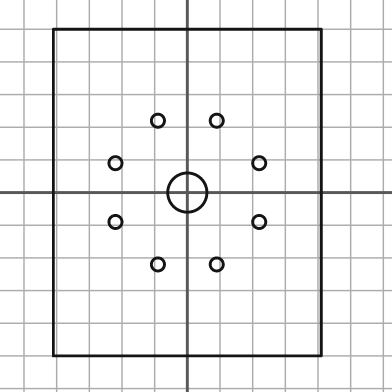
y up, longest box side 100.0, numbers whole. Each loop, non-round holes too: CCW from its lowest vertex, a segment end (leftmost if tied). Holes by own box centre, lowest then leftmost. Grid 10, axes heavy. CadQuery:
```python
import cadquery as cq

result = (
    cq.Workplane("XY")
    .moveTo(-41.0, -50.0)
    .lineTo(41.0, -50.0)
    .lineTo(41.0, 50.0)
    .lineTo(-41.0, 50.0)
    .close()
    .moveTo(-9.0, -22.0)
    .circle(2.0)
    .moveTo(9.0, -22.0)
    .circle(2.0)
    .moveTo(-22.0, -9.0)
    .circle(2.0)
    .moveTo(22.0, -9.0)
    .circle(2.0)
    .moveTo(0.0, 0.0)
    .circle(6.0)
    .moveTo(-22.0, 9.0)
    .circle(2.0)
    .moveTo(22.0, 9.0)
    .circle(2.0)
    .moveTo(-9.0, 22.0)
    .circle(2.0)
    .moveTo(9.0, 22.0)
    .circle(2.0)
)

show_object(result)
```